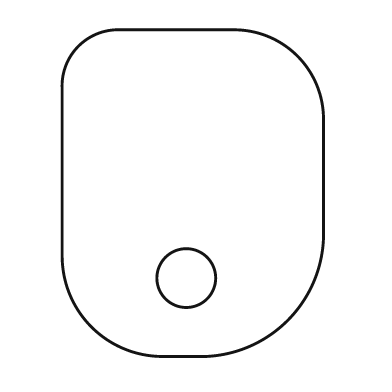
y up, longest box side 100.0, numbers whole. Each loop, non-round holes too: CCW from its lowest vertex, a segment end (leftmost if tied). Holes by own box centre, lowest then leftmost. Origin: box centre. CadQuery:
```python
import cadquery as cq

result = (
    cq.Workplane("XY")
    .moveTo(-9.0, -50.0)
    .lineTo(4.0, -50.0)
    .threePointArc((29.0, -39.0), (40.0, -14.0))
    .lineTo(40.0, 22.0)
    .threePointArc((32.0, 42.0), (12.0, 50.0))
    .lineTo(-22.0, 50.0)
    .threePointArc((-35.0, 45.0), (-40.0, 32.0))
    .lineTo(-40.0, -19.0)
    .threePointArc((-31.0, -41.0), (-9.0, -50.0))
    .close()
    .moveTo(-2.0, -26.0)
    .circle(9.0)
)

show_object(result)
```